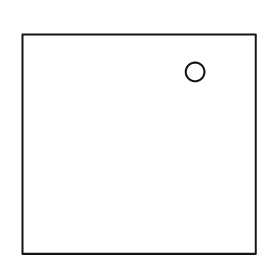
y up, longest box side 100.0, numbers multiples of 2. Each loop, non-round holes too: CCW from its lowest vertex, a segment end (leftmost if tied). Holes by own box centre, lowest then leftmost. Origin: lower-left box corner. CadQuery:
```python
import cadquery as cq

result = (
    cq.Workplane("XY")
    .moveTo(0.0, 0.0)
    .lineTo(100.0, 0.0)
    .lineTo(100.0, 94.0)
    .lineTo(0.0, 94.0)
    .close()
    .moveTo(74.0, 78.0)
    .circle(4.0)
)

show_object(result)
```